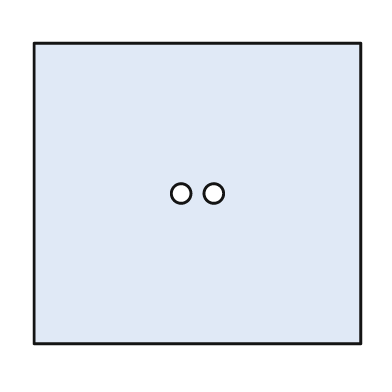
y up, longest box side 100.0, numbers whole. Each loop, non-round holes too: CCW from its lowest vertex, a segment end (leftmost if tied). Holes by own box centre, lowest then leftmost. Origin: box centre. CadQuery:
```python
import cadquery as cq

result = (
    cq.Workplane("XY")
    .moveTo(-50.0, -46.0)
    .lineTo(50.0, -46.0)
    .lineTo(50.0, 46.0)
    .lineTo(-50.0, 46.0)
    .close()
    .moveTo(-5.0, 0.0)
    .circle(3.0)
    .moveTo(5.0, 0.0)
    .circle(3.0)
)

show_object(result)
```